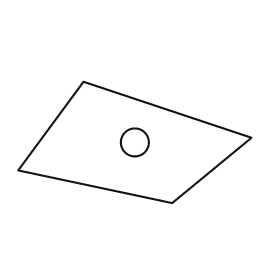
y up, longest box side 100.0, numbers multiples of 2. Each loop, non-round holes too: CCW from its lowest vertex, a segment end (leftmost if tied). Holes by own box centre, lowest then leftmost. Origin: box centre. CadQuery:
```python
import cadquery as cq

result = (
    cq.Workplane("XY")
    .moveTo(16.0, -26.0)
    .lineTo(50.0, 2.0)
    .lineTo(-22.0, 26.0)
    .lineTo(-50.0, -12.0)
    .close()
    .moveTo(0.0, 0.0)
    .circle(6.0)
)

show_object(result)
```